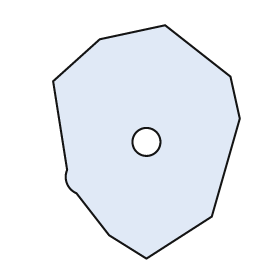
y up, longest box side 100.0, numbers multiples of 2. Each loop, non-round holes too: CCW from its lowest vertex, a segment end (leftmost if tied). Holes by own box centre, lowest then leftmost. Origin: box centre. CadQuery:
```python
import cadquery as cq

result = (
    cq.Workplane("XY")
    .moveTo(0.0, -50.0)
    .lineTo(28.0, -32.0)
    .lineTo(40.0, 10.0)
    .lineTo(36.0, 28.0)
    .lineTo(8.0, 50.0)
    .lineTo(-20.0, 44.0)
    .lineTo(-40.0, 26.0)
    .lineTo(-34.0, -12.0)
    .threePointArc((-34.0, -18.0), (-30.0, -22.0))
    .lineTo(-16.0, -40.0)
    .close()
    .moveTo(0.0, 0.0)
    .circle(6.0)
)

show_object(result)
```